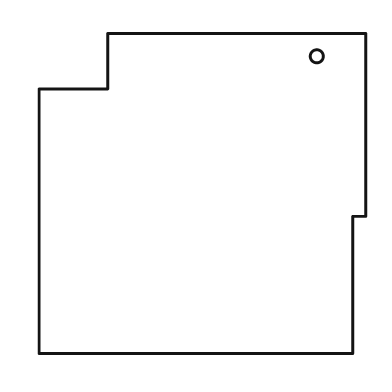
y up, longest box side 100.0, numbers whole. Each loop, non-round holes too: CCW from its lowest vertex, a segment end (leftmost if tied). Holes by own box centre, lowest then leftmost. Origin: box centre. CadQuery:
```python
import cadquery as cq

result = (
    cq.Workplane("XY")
    .moveTo(-50.0, -49.0)
    .lineTo(46.0, -49.0)
    .lineTo(46.0, -7.0)
    .lineTo(50.0, -7.0)
    .lineTo(50.0, 49.0)
    .lineTo(-29.0, 49.0)
    .lineTo(-29.0, 32.0)
    .lineTo(-50.0, 32.0)
    .close()
    .moveTo(35.0, 42.0)
    .circle(2.0)
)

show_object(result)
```